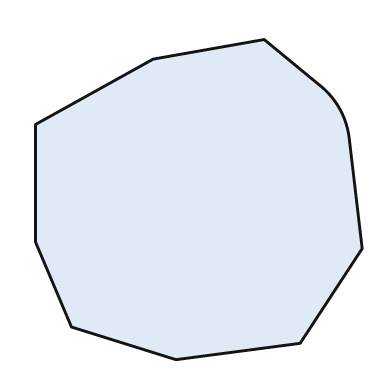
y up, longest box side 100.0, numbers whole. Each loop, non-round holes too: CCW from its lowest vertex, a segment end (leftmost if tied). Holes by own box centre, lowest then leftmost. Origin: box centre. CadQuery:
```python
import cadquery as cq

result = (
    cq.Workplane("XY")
    .moveTo(-7.0, -49.0)
    .lineTo(31.0, -44.0)
    .lineTo(50.0, -15.0)
    .lineTo(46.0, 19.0)
    .threePointArc((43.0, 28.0), (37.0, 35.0))
    .lineTo(20.0, 49.0)
    .lineTo(-14.0, 43.0)
    .lineTo(-50.0, 23.0)
    .lineTo(-50.0, -13.0)
    .lineTo(-39.0, -39.0)
    .close()
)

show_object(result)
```